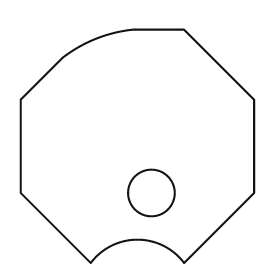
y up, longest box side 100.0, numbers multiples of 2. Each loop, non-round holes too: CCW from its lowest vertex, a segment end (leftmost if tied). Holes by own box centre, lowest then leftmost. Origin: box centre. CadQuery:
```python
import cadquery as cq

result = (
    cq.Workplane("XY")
    .moveTo(-20.0, -50.0)
    .threePointArc((0.0, -40.0), (20.0, -50.0))
    .lineTo(50.0, -20.0)
    .lineTo(50.0, 20.0)
    .lineTo(20.0, 50.0)
    .lineTo(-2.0, 50.0)
    .threePointArc((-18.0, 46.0), (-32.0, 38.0))
    .lineTo(-50.0, 20.0)
    .lineTo(-50.0, -20.0)
    .close()
    .moveTo(6.0, -20.0)
    .circle(10.0)
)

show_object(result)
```